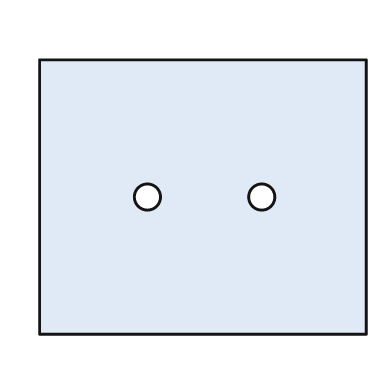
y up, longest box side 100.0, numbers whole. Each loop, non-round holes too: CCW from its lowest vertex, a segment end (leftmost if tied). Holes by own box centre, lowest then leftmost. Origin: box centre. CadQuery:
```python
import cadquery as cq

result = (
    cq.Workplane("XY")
    .moveTo(-50.0, -42.0)
    .lineTo(50.0, -42.0)
    .lineTo(50.0, 42.0)
    .lineTo(-50.0, 42.0)
    .close()
    .moveTo(-17.0, 0.0)
    .circle(4.0)
    .moveTo(18.0, 0.0)
    .circle(4.0)
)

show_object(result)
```